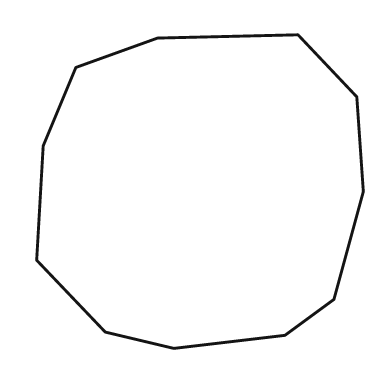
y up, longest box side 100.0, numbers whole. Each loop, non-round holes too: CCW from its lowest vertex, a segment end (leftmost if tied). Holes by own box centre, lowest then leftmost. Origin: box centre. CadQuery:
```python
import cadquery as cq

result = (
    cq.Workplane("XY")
    .moveTo(-8.0, -48.0)
    .lineTo(26.0, -44.0)
    .lineTo(41.0, -33.0)
    .lineTo(50.0, 0.0)
    .lineTo(48.0, 29.0)
    .lineTo(30.0, 48.0)
    .lineTo(-13.0, 47.0)
    .lineTo(-38.0, 38.0)
    .lineTo(-48.0, 14.0)
    .lineTo(-50.0, -21.0)
    .lineTo(-29.0, -43.0)
    .close()
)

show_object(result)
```